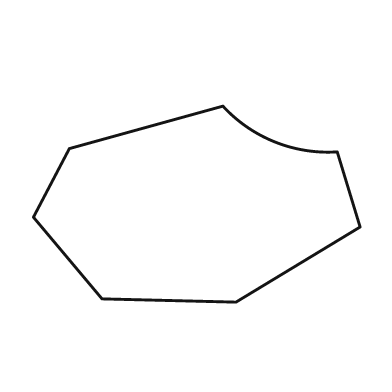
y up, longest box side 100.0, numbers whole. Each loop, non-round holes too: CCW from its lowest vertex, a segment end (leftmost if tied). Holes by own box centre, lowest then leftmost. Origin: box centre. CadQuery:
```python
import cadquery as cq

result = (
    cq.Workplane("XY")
    .moveTo(12.0, -30.0)
    .lineTo(50.0, -7.0)
    .lineTo(43.0, 16.0)
    .threePointArc((24.0, 19.0), (8.0, 30.0))
    .lineTo(-39.0, 17.0)
    .lineTo(-50.0, -4.0)
    .lineTo(-29.0, -29.0)
    .close()
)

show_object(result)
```